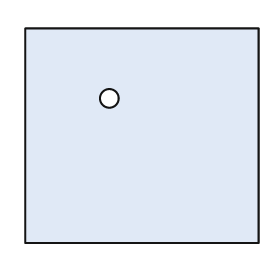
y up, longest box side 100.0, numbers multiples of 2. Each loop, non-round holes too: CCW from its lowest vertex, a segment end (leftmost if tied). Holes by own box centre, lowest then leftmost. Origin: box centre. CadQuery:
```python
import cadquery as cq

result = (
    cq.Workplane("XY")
    .moveTo(-50.0, -46.0)
    .lineTo(50.0, -46.0)
    .lineTo(50.0, 46.0)
    .lineTo(-50.0, 46.0)
    .close()
    .moveTo(-14.0, 16.0)
    .circle(4.0)
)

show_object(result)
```